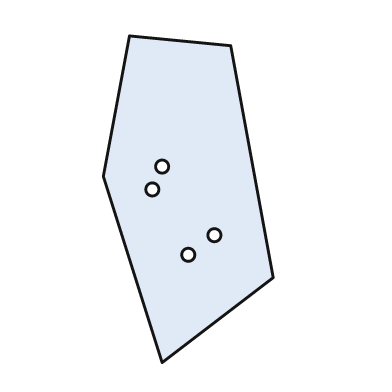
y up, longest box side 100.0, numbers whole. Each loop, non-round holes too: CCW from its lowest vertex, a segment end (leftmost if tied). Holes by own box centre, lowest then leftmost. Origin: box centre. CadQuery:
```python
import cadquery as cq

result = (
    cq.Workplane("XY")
    .moveTo(-8.0, -50.0)
    .lineTo(26.0, -24.0)
    .lineTo(13.0, 47.0)
    .lineTo(-18.0, 50.0)
    .lineTo(-26.0, 7.0)
    .close()
    .moveTo(0.0, -17.0)
    .circle(2.0)
    .moveTo(8.0, -11.0)
    .circle(2.0)
    .moveTo(-11.0, 3.0)
    .circle(2.0)
    .moveTo(-8.0, 10.0)
    .circle(2.0)
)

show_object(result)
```